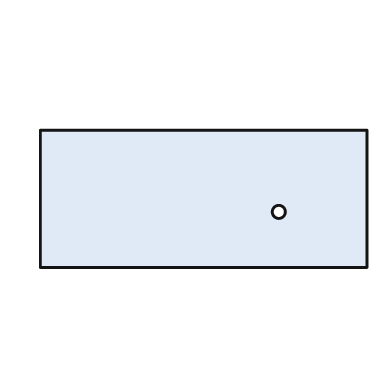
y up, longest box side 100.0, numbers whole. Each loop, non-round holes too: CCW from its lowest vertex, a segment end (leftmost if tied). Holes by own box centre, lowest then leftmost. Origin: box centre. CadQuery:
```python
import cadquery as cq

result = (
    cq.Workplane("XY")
    .moveTo(-50.0, -21.0)
    .lineTo(50.0, -21.0)
    .lineTo(50.0, 21.0)
    .lineTo(-50.0, 21.0)
    .close()
    .moveTo(23.0, -4.0)
    .circle(2.0)
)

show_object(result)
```